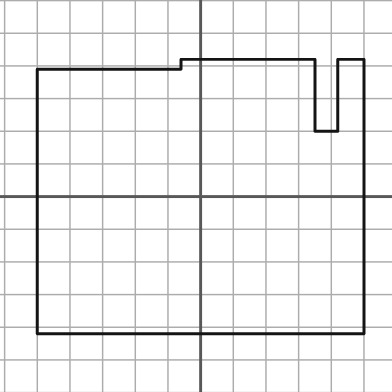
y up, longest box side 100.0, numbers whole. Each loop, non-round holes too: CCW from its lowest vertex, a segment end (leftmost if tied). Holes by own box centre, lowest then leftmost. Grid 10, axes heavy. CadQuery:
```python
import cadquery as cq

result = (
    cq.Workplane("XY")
    .moveTo(-50.0, -42.0)
    .lineTo(50.0, -42.0)
    .lineTo(50.0, 42.0)
    .lineTo(42.0, 42.0)
    .lineTo(42.0, 20.0)
    .lineTo(35.0, 20.0)
    .lineTo(35.0, 42.0)
    .lineTo(-6.0, 42.0)
    .lineTo(-6.0, 39.0)
    .lineTo(-50.0, 39.0)
    .close()
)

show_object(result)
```